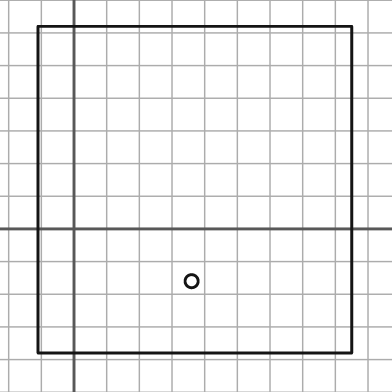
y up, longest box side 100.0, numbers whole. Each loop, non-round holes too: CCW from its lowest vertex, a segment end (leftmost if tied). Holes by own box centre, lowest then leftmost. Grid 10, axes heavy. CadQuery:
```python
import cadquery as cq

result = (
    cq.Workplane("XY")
    .moveTo(-11.0, -38.0)
    .lineTo(85.0, -38.0)
    .lineTo(85.0, 62.0)
    .lineTo(-11.0, 62.0)
    .close()
    .moveTo(36.0, -16.0)
    .circle(2.0)
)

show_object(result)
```